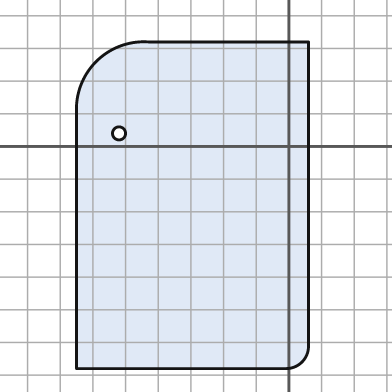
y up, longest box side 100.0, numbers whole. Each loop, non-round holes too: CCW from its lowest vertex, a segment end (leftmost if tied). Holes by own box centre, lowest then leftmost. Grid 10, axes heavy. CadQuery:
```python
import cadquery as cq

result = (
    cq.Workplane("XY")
    .moveTo(-65.0, -68.0)
    .lineTo(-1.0, -68.0)
    .threePointArc((4.0, -66.0), (6.0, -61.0))
    .lineTo(6.0, 32.0)
    .lineTo(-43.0, 32.0)
    .threePointArc((-59.0, 26.0), (-65.0, 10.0))
    .close()
    .moveTo(-52.0, 4.0)
    .circle(2.0)
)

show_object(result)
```